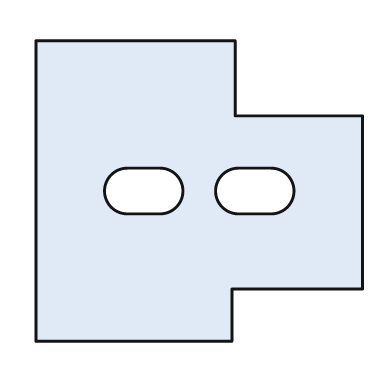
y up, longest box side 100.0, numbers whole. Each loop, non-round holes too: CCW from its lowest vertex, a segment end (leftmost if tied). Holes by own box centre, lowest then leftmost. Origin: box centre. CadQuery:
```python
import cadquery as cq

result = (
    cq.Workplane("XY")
    .moveTo(-50.0, -46.0)
    .lineTo(10.0, -46.0)
    .lineTo(10.0, -30.0)
    .lineTo(50.0, -30.0)
    .lineTo(50.0, 23.0)
    .lineTo(11.0, 23.0)
    .lineTo(11.0, 46.0)
    .lineTo(-50.0, 46.0)
    .close()
    .moveTo(-22.0, -7.0)
    .lineTo(-12.0, -7.0)
    .threePointArc((-5.0, 0.0), (-12.0, 7.0))
    .lineTo(-22.0, 7.0)
    .threePointArc((-29.0, 0.0), (-22.0, -7.0))
    .close()
    .moveTo(12.0, -7.0)
    .lineTo(22.0, -7.0)
    .threePointArc((29.0, 0.0), (22.0, 7.0))
    .lineTo(12.0, 7.0)
    .threePointArc((5.0, 0.0), (12.0, -7.0))
    .close()
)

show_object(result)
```